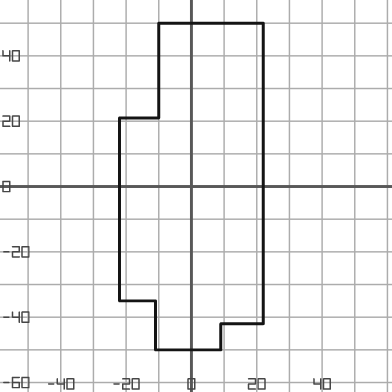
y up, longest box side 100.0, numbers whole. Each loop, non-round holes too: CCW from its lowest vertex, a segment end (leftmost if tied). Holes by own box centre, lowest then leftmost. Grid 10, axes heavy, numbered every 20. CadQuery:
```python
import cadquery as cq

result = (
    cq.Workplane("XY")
    .moveTo(-11.0, -50.0)
    .lineTo(9.0, -50.0)
    .lineTo(9.0, -42.0)
    .lineTo(22.0, -42.0)
    .lineTo(22.0, 50.0)
    .lineTo(-10.0, 50.0)
    .lineTo(-10.0, 21.0)
    .lineTo(-22.0, 21.0)
    .lineTo(-22.0, -35.0)
    .lineTo(-11.0, -35.0)
    .close()
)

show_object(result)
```